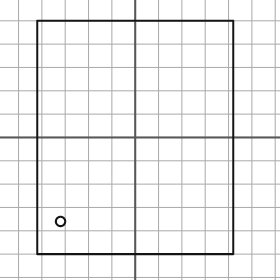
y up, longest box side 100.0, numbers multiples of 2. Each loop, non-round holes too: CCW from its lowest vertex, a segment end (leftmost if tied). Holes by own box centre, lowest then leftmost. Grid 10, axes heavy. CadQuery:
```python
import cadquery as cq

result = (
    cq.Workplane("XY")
    .moveTo(-42.0, -50.0)
    .lineTo(42.0, -50.0)
    .lineTo(42.0, 50.0)
    .lineTo(-42.0, 50.0)
    .close()
    .moveTo(-32.0, -36.0)
    .circle(2.0)
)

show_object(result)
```